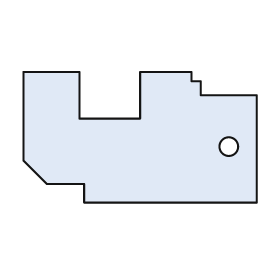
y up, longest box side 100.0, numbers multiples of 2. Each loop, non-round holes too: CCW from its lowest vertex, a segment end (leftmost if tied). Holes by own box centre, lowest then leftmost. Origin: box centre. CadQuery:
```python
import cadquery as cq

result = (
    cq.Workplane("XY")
    .moveTo(-24.0, -28.0)
    .lineTo(50.0, -28.0)
    .lineTo(50.0, 18.0)
    .lineTo(26.0, 18.0)
    .lineTo(26.0, 24.0)
    .lineTo(22.0, 24.0)
    .lineTo(22.0, 28.0)
    .lineTo(0.0, 28.0)
    .lineTo(0.0, 8.0)
    .lineTo(-26.0, 8.0)
    .lineTo(-26.0, 28.0)
    .lineTo(-50.0, 28.0)
    .lineTo(-50.0, -10.0)
    .lineTo(-40.0, -20.0)
    .lineTo(-24.0, -20.0)
    .close()
    .moveTo(38.0, -4.0)
    .circle(4.0)
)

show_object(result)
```